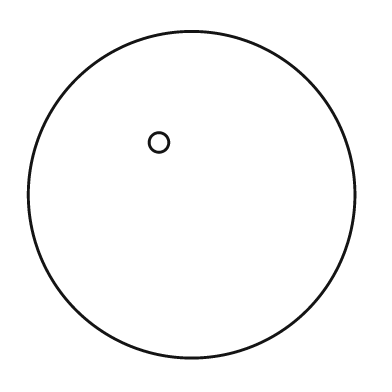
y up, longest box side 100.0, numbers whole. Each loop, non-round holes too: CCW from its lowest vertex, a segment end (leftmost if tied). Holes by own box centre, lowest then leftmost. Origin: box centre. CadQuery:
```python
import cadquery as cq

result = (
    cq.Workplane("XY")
    .moveTo(0.0, 0.0)
    .circle(50.0)
    .moveTo(-10.0, 16.0)
    .circle(3.0)
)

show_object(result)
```